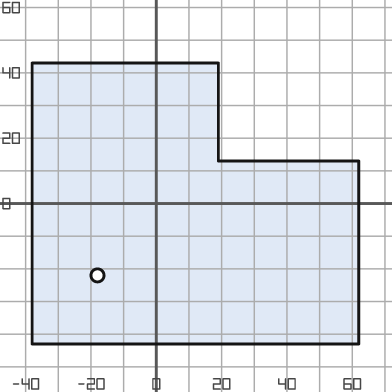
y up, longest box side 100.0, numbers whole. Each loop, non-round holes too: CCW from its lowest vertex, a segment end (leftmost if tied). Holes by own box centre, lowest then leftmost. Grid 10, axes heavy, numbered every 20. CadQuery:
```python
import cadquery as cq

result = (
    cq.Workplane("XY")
    .moveTo(-38.0, -43.0)
    .lineTo(62.0, -43.0)
    .lineTo(62.0, 13.0)
    .lineTo(19.0, 13.0)
    .lineTo(19.0, 43.0)
    .lineTo(-38.0, 43.0)
    .close()
    .moveTo(-18.0, -22.0)
    .circle(2.0)
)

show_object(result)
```